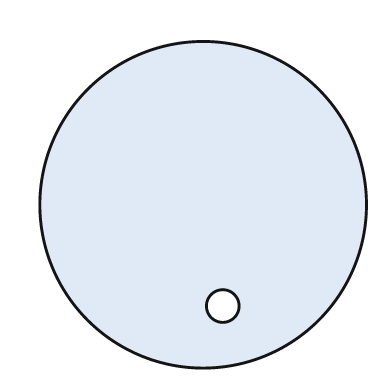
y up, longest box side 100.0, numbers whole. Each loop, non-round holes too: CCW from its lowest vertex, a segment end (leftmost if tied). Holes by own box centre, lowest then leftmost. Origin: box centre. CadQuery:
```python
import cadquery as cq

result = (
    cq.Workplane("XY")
    .moveTo(0.0, 0.0)
    .circle(50.0)
    .moveTo(6.0, -31.0)
    .circle(5.0)
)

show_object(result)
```